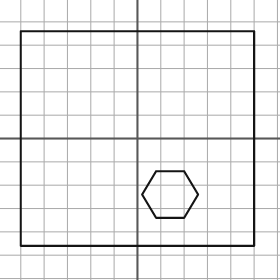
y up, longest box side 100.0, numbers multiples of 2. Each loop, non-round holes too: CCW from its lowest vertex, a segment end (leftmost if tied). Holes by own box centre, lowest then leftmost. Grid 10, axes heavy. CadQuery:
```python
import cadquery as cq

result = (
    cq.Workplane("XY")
    .moveTo(-50.0, -46.0)
    .lineTo(50.0, -46.0)
    .lineTo(50.0, 46.0)
    .lineTo(-50.0, 46.0)
    .close()
    .moveTo(8.0, -34.0)
    .lineTo(20.0, -34.0)
    .lineTo(26.0, -24.0)
    .lineTo(20.0, -14.0)
    .lineTo(8.0, -14.0)
    .lineTo(2.0, -24.0)
    .close()
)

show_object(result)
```